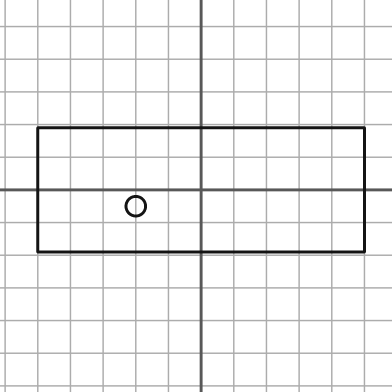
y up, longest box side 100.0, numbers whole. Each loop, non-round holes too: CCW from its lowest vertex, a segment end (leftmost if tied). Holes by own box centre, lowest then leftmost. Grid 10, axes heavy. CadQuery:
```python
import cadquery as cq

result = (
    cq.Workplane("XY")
    .moveTo(-50.0, -19.0)
    .lineTo(50.0, -19.0)
    .lineTo(50.0, 19.0)
    .lineTo(-50.0, 19.0)
    .close()
    .moveTo(-20.0, -5.0)
    .circle(3.0)
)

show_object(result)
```